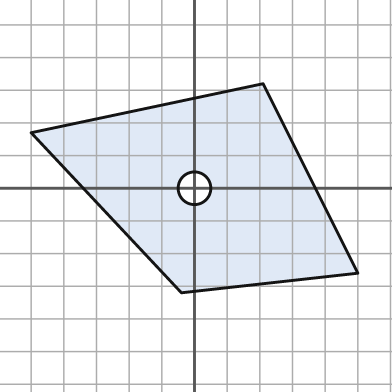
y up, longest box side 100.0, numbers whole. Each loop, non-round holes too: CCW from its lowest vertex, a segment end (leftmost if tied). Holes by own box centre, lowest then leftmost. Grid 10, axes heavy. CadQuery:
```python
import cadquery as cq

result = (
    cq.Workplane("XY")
    .moveTo(-4.0, -32.0)
    .lineTo(50.0, -26.0)
    .lineTo(21.0, 32.0)
    .lineTo(-50.0, 17.0)
    .close()
    .moveTo(0.0, 0.0)
    .circle(5.0)
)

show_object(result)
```